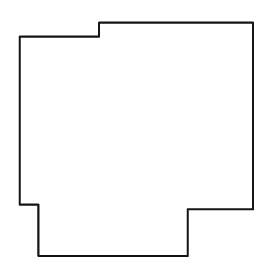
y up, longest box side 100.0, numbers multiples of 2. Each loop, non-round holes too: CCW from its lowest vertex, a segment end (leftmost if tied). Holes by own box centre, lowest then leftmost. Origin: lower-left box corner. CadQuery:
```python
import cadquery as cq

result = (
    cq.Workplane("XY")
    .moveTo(8.0, 0.0)
    .lineTo(72.0, 0.0)
    .lineTo(72.0, 20.0)
    .lineTo(100.0, 20.0)
    .lineTo(100.0, 100.0)
    .lineTo(34.0, 100.0)
    .lineTo(34.0, 94.0)
    .lineTo(0.0, 94.0)
    .lineTo(0.0, 22.0)
    .lineTo(8.0, 22.0)
    .close()
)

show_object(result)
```